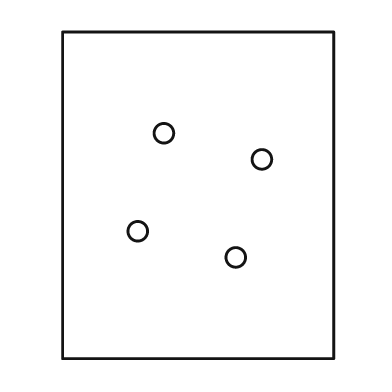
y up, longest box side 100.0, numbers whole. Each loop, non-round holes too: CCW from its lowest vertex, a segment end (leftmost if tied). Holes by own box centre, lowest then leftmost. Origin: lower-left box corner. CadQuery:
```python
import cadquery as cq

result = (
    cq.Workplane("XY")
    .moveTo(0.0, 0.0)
    .lineTo(83.0, 0.0)
    .lineTo(83.0, 100.0)
    .lineTo(0.0, 100.0)
    .close()
    .moveTo(53.0, 31.0)
    .circle(3.0)
    .moveTo(23.0, 39.0)
    .circle(3.0)
    .moveTo(61.0, 61.0)
    .circle(3.0)
    .moveTo(31.0, 69.0)
    .circle(3.0)
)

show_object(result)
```